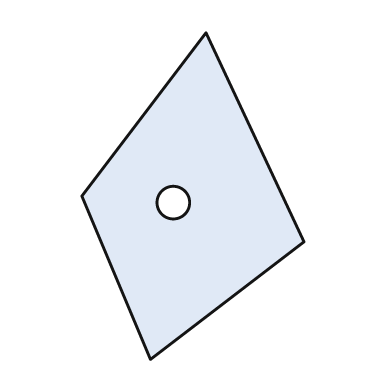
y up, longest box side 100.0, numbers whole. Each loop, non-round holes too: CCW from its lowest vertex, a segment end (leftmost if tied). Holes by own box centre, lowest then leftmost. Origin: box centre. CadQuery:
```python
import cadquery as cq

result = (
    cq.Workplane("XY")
    .moveTo(-13.0, -50.0)
    .lineTo(34.0, -14.0)
    .lineTo(4.0, 50.0)
    .lineTo(-34.0, 0.0)
    .close()
    .moveTo(-6.0, -2.0)
    .circle(5.0)
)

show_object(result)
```